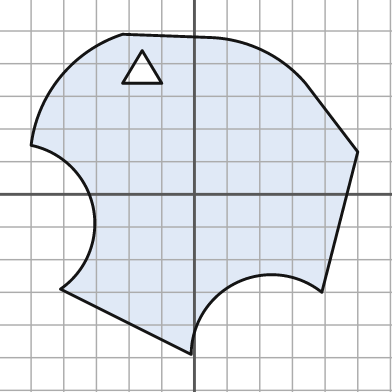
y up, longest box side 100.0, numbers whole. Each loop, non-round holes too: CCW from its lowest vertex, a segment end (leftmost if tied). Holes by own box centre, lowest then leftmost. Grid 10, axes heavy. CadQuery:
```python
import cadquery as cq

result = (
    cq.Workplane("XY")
    .moveTo(-1.0, -49.0)
    .threePointArc((13.0, -27.0), (39.0, -30.0))
    .lineTo(50.0, 13.0)
    .lineTo(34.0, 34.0)
    .threePointArc((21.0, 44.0), (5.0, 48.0))
    .lineTo(-22.0, 49.0)
    .threePointArc((-41.0, 36.0), (-50.0, 15.0))
    .threePointArc((-31.0, -4.0), (-41.0, -29.0))
    .close()
    .moveTo(-22.0, 34.0)
    .lineTo(-10.0, 34.0)
    .lineTo(-16.0, 44.0)
    .close()
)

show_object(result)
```